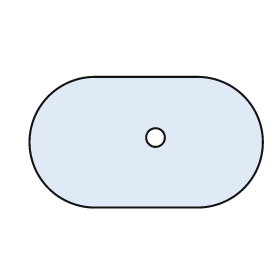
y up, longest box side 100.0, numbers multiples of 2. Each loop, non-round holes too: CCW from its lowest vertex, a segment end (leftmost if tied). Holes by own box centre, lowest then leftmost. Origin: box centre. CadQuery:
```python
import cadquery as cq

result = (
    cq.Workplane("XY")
    .moveTo(-22.0, -28.0)
    .lineTo(22.0, -28.0)
    .threePointArc((50.0, 0.0), (22.0, 28.0))
    .lineTo(-22.0, 28.0)
    .threePointArc((-50.0, 0.0), (-22.0, -28.0))
    .close()
    .moveTo(4.0, 2.0)
    .circle(4.0)
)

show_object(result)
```